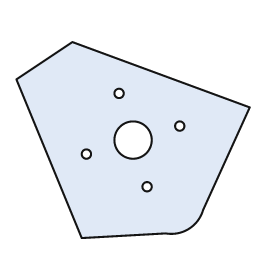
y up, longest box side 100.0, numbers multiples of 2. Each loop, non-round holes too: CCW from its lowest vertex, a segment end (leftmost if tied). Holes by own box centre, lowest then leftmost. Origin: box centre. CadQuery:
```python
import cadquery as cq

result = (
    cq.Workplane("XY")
    .moveTo(-22.0, -42.0)
    .lineTo(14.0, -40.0)
    .threePointArc((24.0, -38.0), (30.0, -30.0))
    .lineTo(50.0, 14.0)
    .lineTo(-26.0, 42.0)
    .lineTo(-50.0, 26.0)
    .close()
    .moveTo(6.0, -20.0)
    .circle(2.0)
    .moveTo(-20.0, -6.0)
    .circle(2.0)
    .moveTo(0.0, 0.0)
    .circle(8.0)
    .moveTo(20.0, 6.0)
    .circle(2.0)
    .moveTo(-6.0, 20.0)
    .circle(2.0)
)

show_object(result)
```